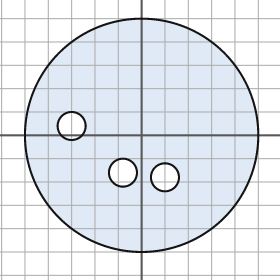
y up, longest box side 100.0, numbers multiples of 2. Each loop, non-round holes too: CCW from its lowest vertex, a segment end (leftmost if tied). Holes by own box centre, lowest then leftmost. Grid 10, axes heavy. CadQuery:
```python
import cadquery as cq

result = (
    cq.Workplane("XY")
    .moveTo(0.0, 0.0)
    .circle(50.0)
    .moveTo(10.0, -18.0)
    .circle(6.0)
    .moveTo(-8.0, -16.0)
    .circle(6.0)
    .moveTo(-30.0, 4.0)
    .circle(6.0)
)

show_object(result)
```